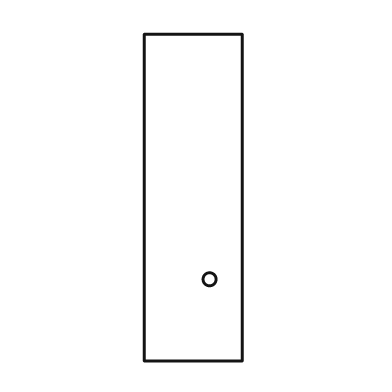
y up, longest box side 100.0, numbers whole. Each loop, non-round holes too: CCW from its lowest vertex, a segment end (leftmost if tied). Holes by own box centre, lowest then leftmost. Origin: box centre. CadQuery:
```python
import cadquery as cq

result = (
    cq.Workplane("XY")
    .moveTo(-15.0, -50.0)
    .lineTo(15.0, -50.0)
    .lineTo(15.0, 50.0)
    .lineTo(-15.0, 50.0)
    .close()
    .moveTo(5.0, -25.0)
    .circle(2.0)
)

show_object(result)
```